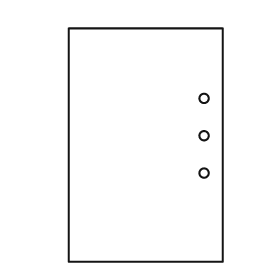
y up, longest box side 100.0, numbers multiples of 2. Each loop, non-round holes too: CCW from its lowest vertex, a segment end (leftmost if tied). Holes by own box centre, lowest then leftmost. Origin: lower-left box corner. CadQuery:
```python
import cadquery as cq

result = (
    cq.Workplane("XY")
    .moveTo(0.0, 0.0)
    .lineTo(66.0, 0.0)
    .lineTo(66.0, 100.0)
    .lineTo(0.0, 100.0)
    .close()
    .moveTo(58.0, 38.0)
    .circle(2.0)
    .moveTo(58.0, 54.0)
    .circle(2.0)
    .moveTo(58.0, 70.0)
    .circle(2.0)
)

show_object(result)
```